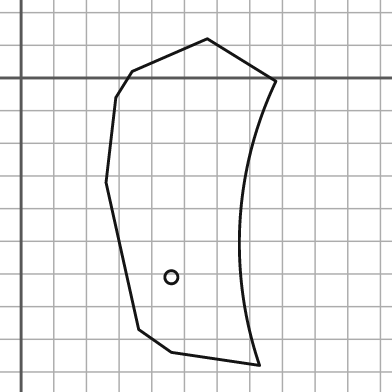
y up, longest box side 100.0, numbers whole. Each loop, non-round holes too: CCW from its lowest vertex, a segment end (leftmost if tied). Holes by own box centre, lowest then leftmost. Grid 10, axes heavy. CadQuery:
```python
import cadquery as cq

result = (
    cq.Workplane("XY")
    .moveTo(73.0, -88.0)
    .threePointArc((67.0, -44.0), (78.0, -1.0))
    .lineTo(57.0, 12.0)
    .lineTo(34.0, 2.0)
    .lineTo(29.0, -6.0)
    .lineTo(26.0, -32.0)
    .lineTo(36.0, -77.0)
    .lineTo(46.0, -84.0)
    .close()
    .moveTo(46.0, -61.0)
    .circle(2.0)
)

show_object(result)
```